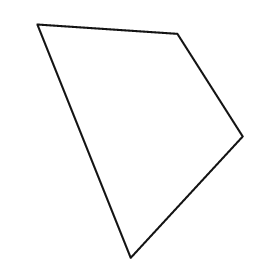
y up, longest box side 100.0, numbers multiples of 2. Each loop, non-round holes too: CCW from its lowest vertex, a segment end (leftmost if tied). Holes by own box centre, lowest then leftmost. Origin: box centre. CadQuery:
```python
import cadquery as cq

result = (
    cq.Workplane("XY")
    .moveTo(-4.0, -50.0)
    .lineTo(44.0, 2.0)
    .lineTo(16.0, 46.0)
    .lineTo(-44.0, 50.0)
    .close()
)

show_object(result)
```